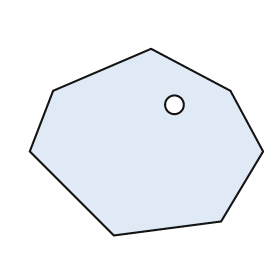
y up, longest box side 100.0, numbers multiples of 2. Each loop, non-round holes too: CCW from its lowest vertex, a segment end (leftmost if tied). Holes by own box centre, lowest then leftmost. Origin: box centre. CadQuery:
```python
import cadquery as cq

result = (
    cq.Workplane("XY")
    .moveTo(-14.0, -40.0)
    .lineTo(32.0, -34.0)
    .lineTo(50.0, -4.0)
    .lineTo(36.0, 22.0)
    .lineTo(2.0, 40.0)
    .lineTo(-40.0, 22.0)
    .lineTo(-50.0, -4.0)
    .close()
    .moveTo(12.0, 16.0)
    .circle(4.0)
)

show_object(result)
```